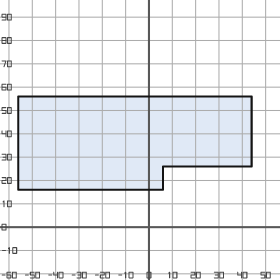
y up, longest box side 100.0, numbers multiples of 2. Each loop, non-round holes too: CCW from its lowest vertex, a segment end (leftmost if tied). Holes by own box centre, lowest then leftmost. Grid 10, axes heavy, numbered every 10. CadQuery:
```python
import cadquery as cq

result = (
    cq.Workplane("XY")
    .moveTo(-56.0, 16.0)
    .lineTo(6.0, 16.0)
    .lineTo(6.0, 26.0)
    .lineTo(44.0, 26.0)
    .lineTo(44.0, 56.0)
    .lineTo(-56.0, 56.0)
    .close()
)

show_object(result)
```